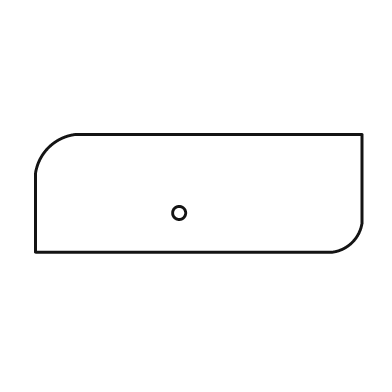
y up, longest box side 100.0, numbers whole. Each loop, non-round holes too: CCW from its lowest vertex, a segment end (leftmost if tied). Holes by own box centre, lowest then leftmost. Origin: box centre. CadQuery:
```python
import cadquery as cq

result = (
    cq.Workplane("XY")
    .moveTo(-50.0, -18.0)
    .lineTo(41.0, -18.0)
    .threePointArc((47.0, -15.0), (50.0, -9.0))
    .lineTo(50.0, 18.0)
    .lineTo(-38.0, 18.0)
    .threePointArc((-46.0, 14.0), (-50.0, 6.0))
    .close()
    .moveTo(-6.0, -6.0)
    .circle(2.0)
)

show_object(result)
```